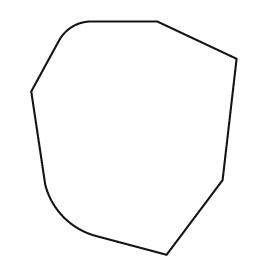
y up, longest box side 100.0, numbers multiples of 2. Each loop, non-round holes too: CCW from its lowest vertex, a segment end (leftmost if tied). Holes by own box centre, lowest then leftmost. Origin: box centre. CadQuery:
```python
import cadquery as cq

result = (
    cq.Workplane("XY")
    .moveTo(14.0, -50.0)
    .lineTo(38.0, -18.0)
    .lineTo(44.0, 34.0)
    .lineTo(10.0, 50.0)
    .lineTo(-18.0, 50.0)
    .threePointArc((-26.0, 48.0), (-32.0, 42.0))
    .lineTo(-44.0, 20.0)
    .lineTo(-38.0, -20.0)
    .threePointArc((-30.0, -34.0), (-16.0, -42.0))
    .close()
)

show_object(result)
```